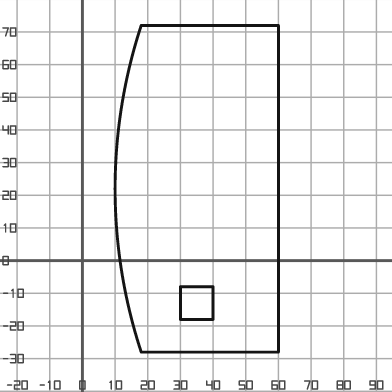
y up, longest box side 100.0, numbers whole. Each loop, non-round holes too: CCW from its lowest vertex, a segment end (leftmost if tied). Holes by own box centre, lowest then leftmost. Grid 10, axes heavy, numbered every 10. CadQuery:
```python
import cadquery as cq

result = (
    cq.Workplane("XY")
    .moveTo(18.0, -28.0)
    .lineTo(60.0, -28.0)
    .lineTo(60.0, 72.0)
    .lineTo(18.0, 72.0)
    .threePointArc((10.0, 22.0), (18.0, -28.0))
    .close()
    .moveTo(30.0, -18.0)
    .lineTo(40.0, -18.0)
    .lineTo(40.0, -8.0)
    .lineTo(30.0, -8.0)
    .close()
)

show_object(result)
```